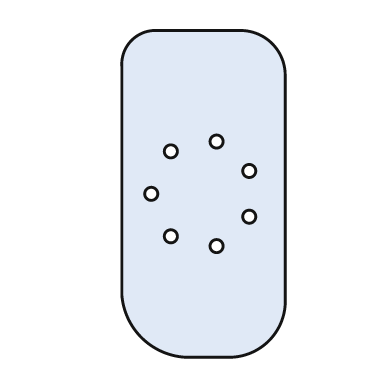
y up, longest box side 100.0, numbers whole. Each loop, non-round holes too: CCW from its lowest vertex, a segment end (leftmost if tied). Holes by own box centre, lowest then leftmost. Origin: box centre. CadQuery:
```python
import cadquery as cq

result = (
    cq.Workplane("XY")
    .moveTo(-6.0, -50.0)
    .lineTo(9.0, -50.0)
    .threePointArc((20.0, -45.0), (25.0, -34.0))
    .lineTo(25.0, 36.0)
    .threePointArc((21.0, 46.0), (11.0, 50.0))
    .lineTo(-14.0, 50.0)
    .threePointArc((-22.0, 47.0), (-25.0, 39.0))
    .lineTo(-25.0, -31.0)
    .threePointArc((-19.0, -44.0), (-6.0, -50.0))
    .close()
    .moveTo(4.0, -16.0)
    .circle(2.0)
    .moveTo(-10.0, -13.0)
    .circle(2.0)
    .moveTo(14.0, -7.0)
    .circle(2.0)
    .moveTo(-16.0, 0.0)
    .circle(2.0)
    .moveTo(14.0, 7.0)
    .circle(2.0)
    .moveTo(-10.0, 13.0)
    .circle(2.0)
    .moveTo(4.0, 16.0)
    .circle(2.0)
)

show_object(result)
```